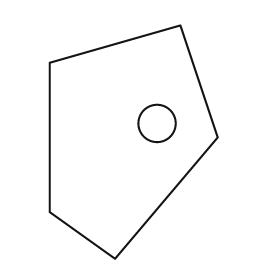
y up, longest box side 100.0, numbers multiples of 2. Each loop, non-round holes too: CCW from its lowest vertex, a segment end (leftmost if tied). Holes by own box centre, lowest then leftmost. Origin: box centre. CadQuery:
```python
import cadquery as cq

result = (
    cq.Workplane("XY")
    .moveTo(-8.0, -50.0)
    .lineTo(36.0, 2.0)
    .lineTo(20.0, 50.0)
    .lineTo(-36.0, 34.0)
    .lineTo(-36.0, -30.0)
    .close()
    .moveTo(10.0, 8.0)
    .circle(8.0)
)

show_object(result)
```